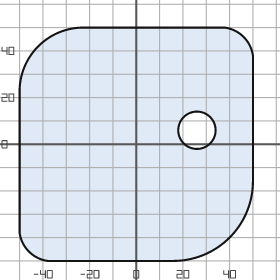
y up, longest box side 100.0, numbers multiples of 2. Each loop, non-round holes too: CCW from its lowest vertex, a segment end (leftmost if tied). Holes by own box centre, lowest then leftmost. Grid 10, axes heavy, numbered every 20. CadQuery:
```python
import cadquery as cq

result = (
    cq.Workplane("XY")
    .moveTo(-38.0, -50.0)
    .lineTo(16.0, -50.0)
    .threePointArc((40.0, -40.0), (50.0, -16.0))
    .lineTo(50.0, 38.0)
    .threePointArc((46.0, 46.0), (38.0, 50.0))
    .lineTo(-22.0, 50.0)
    .threePointArc((-42.0, 42.0), (-50.0, 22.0))
    .lineTo(-50.0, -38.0)
    .threePointArc((-46.0, -46.0), (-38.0, -50.0))
    .close()
    .moveTo(26.0, 6.0)
    .circle(8.0)
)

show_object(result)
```